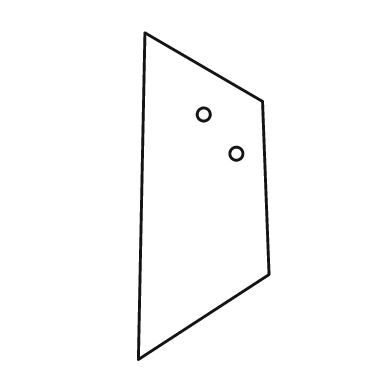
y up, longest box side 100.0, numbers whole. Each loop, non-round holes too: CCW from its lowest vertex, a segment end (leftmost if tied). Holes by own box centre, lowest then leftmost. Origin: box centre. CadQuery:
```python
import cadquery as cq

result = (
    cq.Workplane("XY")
    .moveTo(-20.0, -50.0)
    .lineTo(20.0, -24.0)
    .lineTo(18.0, 29.0)
    .lineTo(-18.0, 50.0)
    .close()
    .moveTo(10.0, 13.0)
    .circle(2.0)
    .moveTo(0.0, 25.0)
    .circle(2.0)
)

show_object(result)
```